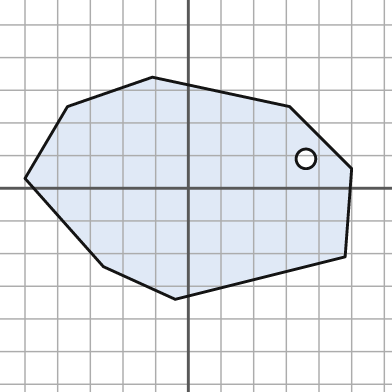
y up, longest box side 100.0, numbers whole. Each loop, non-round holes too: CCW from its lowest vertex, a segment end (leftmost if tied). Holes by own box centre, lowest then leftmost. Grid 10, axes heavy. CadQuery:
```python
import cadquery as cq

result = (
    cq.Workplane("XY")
    .moveTo(-4.0, -34.0)
    .lineTo(48.0, -21.0)
    .lineTo(50.0, 6.0)
    .lineTo(31.0, 25.0)
    .lineTo(-11.0, 34.0)
    .lineTo(-37.0, 25.0)
    .lineTo(-50.0, 3.0)
    .lineTo(-26.0, -24.0)
    .close()
    .moveTo(36.0, 9.0)
    .circle(3.0)
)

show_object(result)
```